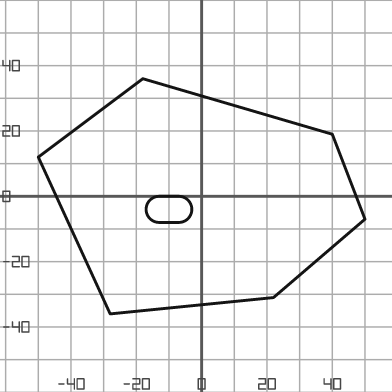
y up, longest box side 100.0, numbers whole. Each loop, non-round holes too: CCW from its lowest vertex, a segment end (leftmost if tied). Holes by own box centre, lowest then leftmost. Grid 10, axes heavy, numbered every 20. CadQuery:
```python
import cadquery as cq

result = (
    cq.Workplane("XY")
    .moveTo(-28.0, -36.0)
    .lineTo(22.0, -31.0)
    .lineTo(50.0, -7.0)
    .lineTo(40.0, 19.0)
    .lineTo(-18.0, 36.0)
    .lineTo(-50.0, 12.0)
    .close()
    .moveTo(-13.0, -8.0)
    .lineTo(-7.0, -8.0)
    .threePointArc((-3.0, -4.0), (-7.0, 0.0))
    .lineTo(-13.0, 0.0)
    .threePointArc((-17.0, -4.0), (-13.0, -8.0))
    .close()
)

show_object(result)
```